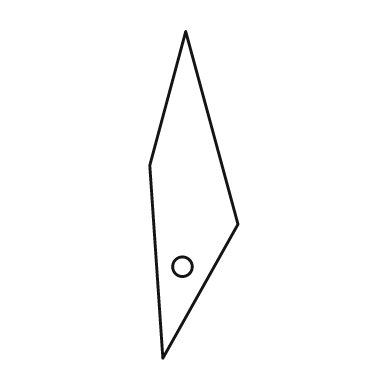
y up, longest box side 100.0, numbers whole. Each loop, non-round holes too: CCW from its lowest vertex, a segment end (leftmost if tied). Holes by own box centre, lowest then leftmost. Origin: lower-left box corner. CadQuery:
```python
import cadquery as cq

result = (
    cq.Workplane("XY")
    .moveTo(4.0, 0.0)
    .lineTo(27.0, 41.0)
    .lineTo(11.0, 100.0)
    .lineTo(0.0, 59.0)
    .close()
    .moveTo(10.0, 28.0)
    .circle(3.0)
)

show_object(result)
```